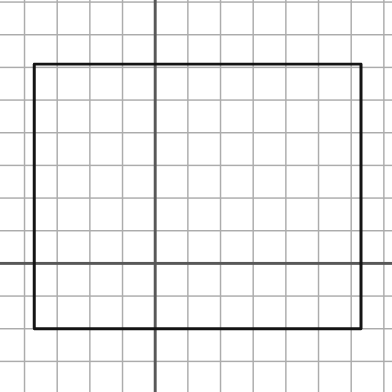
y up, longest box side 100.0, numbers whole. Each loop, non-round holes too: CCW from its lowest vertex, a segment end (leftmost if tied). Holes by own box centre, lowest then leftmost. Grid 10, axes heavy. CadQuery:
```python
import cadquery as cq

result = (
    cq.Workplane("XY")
    .moveTo(-37.0, -20.0)
    .lineTo(63.0, -20.0)
    .lineTo(63.0, 61.0)
    .lineTo(-37.0, 61.0)
    .close()
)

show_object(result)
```